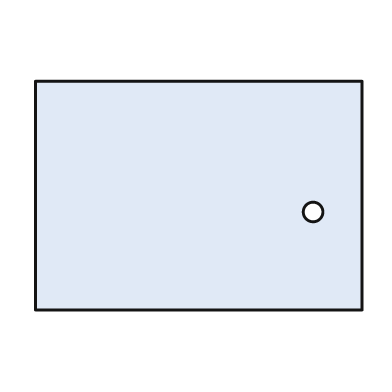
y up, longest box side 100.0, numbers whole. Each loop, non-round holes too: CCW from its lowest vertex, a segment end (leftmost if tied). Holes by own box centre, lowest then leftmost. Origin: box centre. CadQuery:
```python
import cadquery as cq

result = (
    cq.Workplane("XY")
    .moveTo(-50.0, -35.0)
    .lineTo(50.0, -35.0)
    .lineTo(50.0, 35.0)
    .lineTo(-50.0, 35.0)
    .close()
    .moveTo(35.0, -5.0)
    .circle(3.0)
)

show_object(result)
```